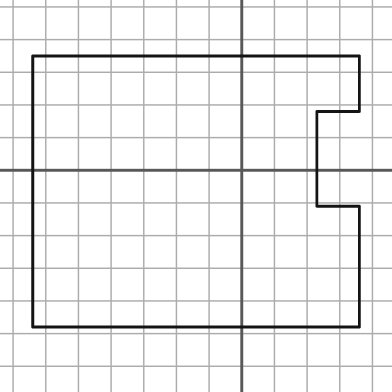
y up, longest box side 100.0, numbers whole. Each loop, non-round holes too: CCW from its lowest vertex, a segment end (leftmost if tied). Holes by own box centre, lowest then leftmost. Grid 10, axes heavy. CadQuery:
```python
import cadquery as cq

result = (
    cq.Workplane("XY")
    .moveTo(-64.0, -48.0)
    .lineTo(36.0, -48.0)
    .lineTo(36.0, -11.0)
    .lineTo(23.0, -11.0)
    .lineTo(23.0, 18.0)
    .lineTo(36.0, 18.0)
    .lineTo(36.0, 35.0)
    .lineTo(-64.0, 35.0)
    .close()
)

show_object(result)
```